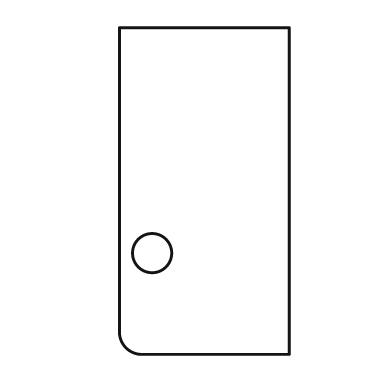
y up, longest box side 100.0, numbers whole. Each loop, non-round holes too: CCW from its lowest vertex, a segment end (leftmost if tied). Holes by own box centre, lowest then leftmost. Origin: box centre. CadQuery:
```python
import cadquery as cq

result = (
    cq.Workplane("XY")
    .moveTo(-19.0, -50.0)
    .lineTo(26.0, -50.0)
    .lineTo(26.0, 50.0)
    .lineTo(-26.0, 50.0)
    .lineTo(-26.0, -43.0)
    .threePointArc((-24.0, -48.0), (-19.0, -50.0))
    .close()
    .moveTo(-16.0, -19.0)
    .circle(6.0)
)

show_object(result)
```